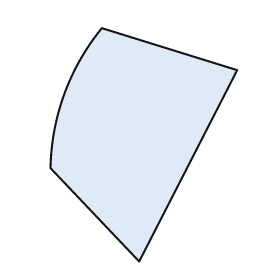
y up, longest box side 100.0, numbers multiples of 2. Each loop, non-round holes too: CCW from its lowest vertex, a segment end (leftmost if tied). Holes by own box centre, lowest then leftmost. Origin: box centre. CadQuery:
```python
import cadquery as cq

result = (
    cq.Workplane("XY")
    .moveTo(-2.0, -50.0)
    .lineTo(40.0, 32.0)
    .lineTo(-18.0, 50.0)
    .threePointArc((-34.0, 22.0), (-40.0, -10.0))
    .close()
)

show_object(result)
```